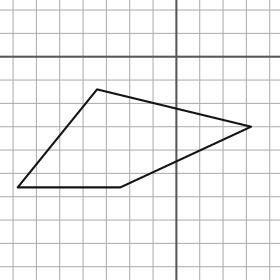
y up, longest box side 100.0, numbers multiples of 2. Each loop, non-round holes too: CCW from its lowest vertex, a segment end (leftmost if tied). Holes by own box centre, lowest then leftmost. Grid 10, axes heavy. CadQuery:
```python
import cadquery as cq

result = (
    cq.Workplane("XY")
    .moveTo(-68.0, -56.0)
    .lineTo(-24.0, -56.0)
    .lineTo(32.0, -30.0)
    .lineTo(-34.0, -14.0)
    .close()
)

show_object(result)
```